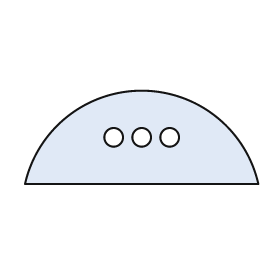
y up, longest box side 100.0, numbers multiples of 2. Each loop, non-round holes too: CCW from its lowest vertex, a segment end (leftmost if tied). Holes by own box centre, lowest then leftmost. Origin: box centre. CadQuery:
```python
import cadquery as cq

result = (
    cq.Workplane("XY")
    .moveTo(-50.0, -20.0)
    .lineTo(50.0, -20.0)
    .threePointArc((0.0, 20.0), (-50.0, -20.0))
    .close()
    .moveTo(-12.0, 0.0)
    .circle(4.0)
    .moveTo(0.0, 0.0)
    .circle(4.0)
    .moveTo(12.0, 0.0)
    .circle(4.0)
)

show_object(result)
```